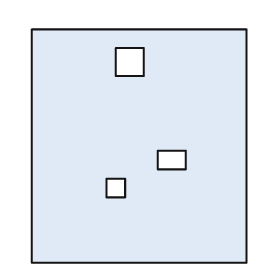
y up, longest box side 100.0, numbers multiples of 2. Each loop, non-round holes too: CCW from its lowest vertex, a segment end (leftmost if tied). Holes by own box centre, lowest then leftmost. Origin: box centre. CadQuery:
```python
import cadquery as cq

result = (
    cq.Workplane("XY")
    .moveTo(-46.0, -50.0)
    .lineTo(46.0, -50.0)
    .lineTo(46.0, 50.0)
    .lineTo(-46.0, 50.0)
    .close()
    .moveTo(-14.0, -22.0)
    .lineTo(-6.0, -22.0)
    .lineTo(-6.0, -14.0)
    .lineTo(-14.0, -14.0)
    .close()
    .moveTo(8.0, -10.0)
    .lineTo(20.0, -10.0)
    .lineTo(20.0, -2.0)
    .lineTo(8.0, -2.0)
    .close()
    .moveTo(-10.0, 30.0)
    .lineTo(2.0, 30.0)
    .lineTo(2.0, 42.0)
    .lineTo(-10.0, 42.0)
    .close()
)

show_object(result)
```